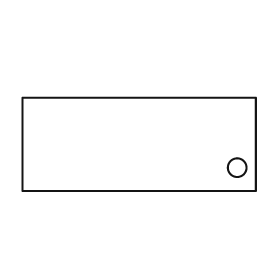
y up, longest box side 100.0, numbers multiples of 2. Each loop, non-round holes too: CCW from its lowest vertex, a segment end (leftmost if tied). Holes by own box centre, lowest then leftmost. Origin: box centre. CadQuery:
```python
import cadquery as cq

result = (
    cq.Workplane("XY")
    .moveTo(-50.0, -20.0)
    .lineTo(50.0, -20.0)
    .lineTo(50.0, 20.0)
    .lineTo(-50.0, 20.0)
    .close()
    .moveTo(42.0, -10.0)
    .circle(4.0)
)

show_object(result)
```